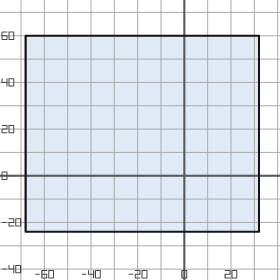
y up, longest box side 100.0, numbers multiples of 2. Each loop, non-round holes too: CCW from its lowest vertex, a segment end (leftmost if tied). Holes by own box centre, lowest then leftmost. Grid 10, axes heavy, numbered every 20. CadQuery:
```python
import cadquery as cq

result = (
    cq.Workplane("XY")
    .moveTo(-68.0, -24.0)
    .lineTo(32.0, -24.0)
    .lineTo(32.0, 60.0)
    .lineTo(-68.0, 60.0)
    .close()
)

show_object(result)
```